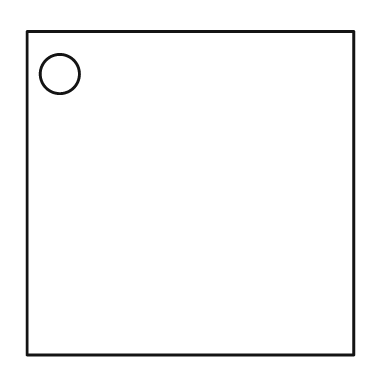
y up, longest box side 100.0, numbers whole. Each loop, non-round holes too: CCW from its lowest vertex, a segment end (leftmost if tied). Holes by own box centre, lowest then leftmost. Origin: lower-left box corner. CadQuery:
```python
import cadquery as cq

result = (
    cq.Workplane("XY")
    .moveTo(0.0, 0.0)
    .lineTo(100.0, 0.0)
    .lineTo(100.0, 99.0)
    .lineTo(0.0, 99.0)
    .close()
    .moveTo(10.0, 86.0)
    .circle(6.0)
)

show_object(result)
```